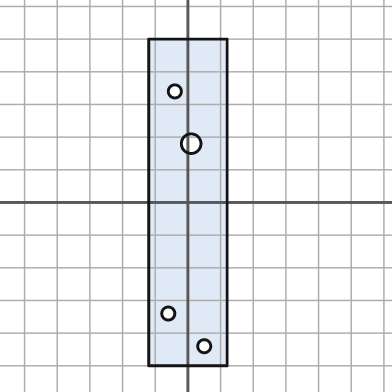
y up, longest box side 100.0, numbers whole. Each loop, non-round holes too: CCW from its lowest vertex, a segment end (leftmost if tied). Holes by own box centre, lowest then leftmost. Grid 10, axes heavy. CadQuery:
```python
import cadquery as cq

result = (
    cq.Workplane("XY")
    .moveTo(-12.0, -50.0)
    .lineTo(12.0, -50.0)
    .lineTo(12.0, 50.0)
    .lineTo(-12.0, 50.0)
    .close()
    .moveTo(5.0, -44.0)
    .circle(2.0)
    .moveTo(-6.0, -34.0)
    .circle(2.0)
    .moveTo(1.0, 18.0)
    .circle(3.0)
    .moveTo(-4.0, 34.0)
    .circle(2.0)
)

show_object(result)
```